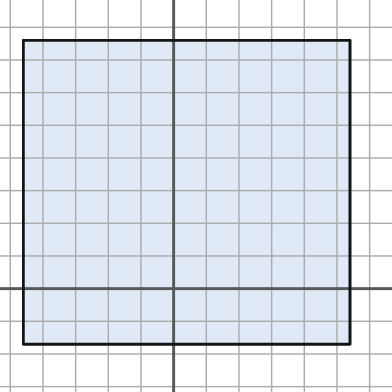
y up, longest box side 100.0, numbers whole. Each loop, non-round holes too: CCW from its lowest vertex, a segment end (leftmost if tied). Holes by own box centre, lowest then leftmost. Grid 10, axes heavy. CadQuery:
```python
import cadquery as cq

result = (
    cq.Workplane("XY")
    .moveTo(-46.0, -17.0)
    .lineTo(54.0, -17.0)
    .lineTo(54.0, 76.0)
    .lineTo(-46.0, 76.0)
    .close()
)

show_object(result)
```